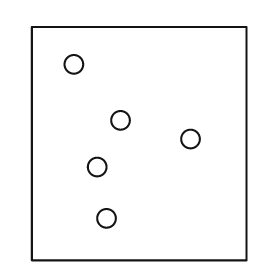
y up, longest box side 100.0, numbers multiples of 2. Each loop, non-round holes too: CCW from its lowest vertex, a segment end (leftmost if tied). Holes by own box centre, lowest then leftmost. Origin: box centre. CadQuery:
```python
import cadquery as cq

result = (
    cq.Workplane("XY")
    .moveTo(-46.0, -50.0)
    .lineTo(46.0, -50.0)
    .lineTo(46.0, 50.0)
    .lineTo(-46.0, 50.0)
    .close()
    .moveTo(-14.0, -32.0)
    .circle(4.0)
    .moveTo(-18.0, -10.0)
    .circle(4.0)
    .moveTo(22.0, 2.0)
    .circle(4.0)
    .moveTo(-8.0, 10.0)
    .circle(4.0)
    .moveTo(-28.0, 34.0)
    .circle(4.0)
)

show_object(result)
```